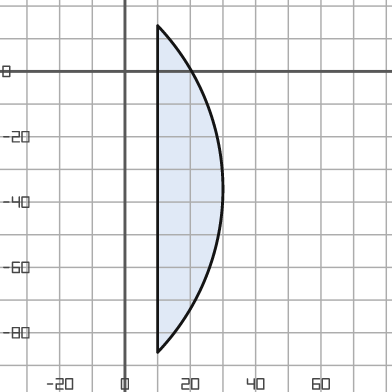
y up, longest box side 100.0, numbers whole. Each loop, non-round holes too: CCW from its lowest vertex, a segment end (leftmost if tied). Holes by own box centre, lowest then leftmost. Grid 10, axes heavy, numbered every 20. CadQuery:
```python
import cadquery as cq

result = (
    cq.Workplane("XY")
    .moveTo(10.0, -86.0)
    .threePointArc((30.0, -36.0), (10.0, 14.0))
    .close()
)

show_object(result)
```